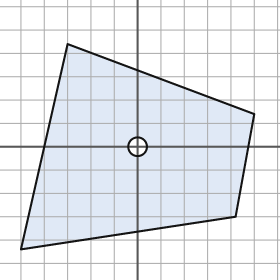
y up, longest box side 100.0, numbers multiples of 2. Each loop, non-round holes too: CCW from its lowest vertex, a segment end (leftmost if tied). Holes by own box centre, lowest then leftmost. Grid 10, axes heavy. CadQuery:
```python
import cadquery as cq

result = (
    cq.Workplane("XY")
    .moveTo(-50.0, -44.0)
    .lineTo(42.0, -30.0)
    .lineTo(50.0, 14.0)
    .lineTo(-30.0, 44.0)
    .close()
    .moveTo(0.0, 0.0)
    .circle(4.0)
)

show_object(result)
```